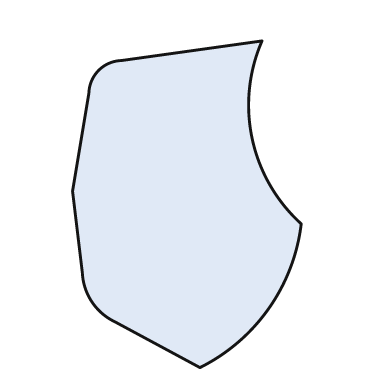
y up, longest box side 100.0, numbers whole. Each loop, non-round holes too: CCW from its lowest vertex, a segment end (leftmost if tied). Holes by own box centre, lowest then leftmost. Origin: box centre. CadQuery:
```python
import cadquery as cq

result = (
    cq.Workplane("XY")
    .moveTo(4.0, -50.0)
    .threePointArc((25.0, -32.0), (35.0, -6.0))
    .threePointArc((20.0, 20.0), (23.0, 50.0))
    .lineTo(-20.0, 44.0)
    .threePointArc((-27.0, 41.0), (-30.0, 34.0))
    .lineTo(-35.0, 4.0)
    .lineTo(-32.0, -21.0)
    .threePointArc((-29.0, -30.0), (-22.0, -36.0))
    .close()
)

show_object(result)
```